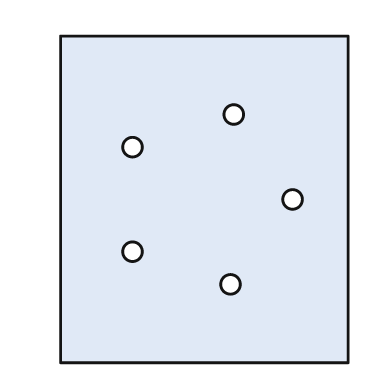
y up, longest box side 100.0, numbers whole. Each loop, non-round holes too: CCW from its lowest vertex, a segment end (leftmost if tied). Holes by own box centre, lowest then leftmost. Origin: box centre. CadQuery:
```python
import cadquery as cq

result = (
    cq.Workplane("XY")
    .moveTo(-44.0, -50.0)
    .lineTo(44.0, -50.0)
    .lineTo(44.0, 50.0)
    .lineTo(-44.0, 50.0)
    .close()
    .moveTo(8.0, -26.0)
    .circle(3.0)
    .moveTo(-22.0, -16.0)
    .circle(3.0)
    .moveTo(27.0, 0.0)
    .circle(3.0)
    .moveTo(-22.0, 16.0)
    .circle(3.0)
    .moveTo(9.0, 26.0)
    .circle(3.0)
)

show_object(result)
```